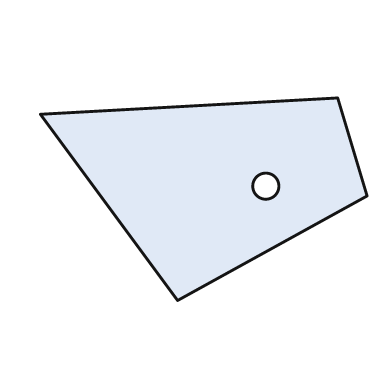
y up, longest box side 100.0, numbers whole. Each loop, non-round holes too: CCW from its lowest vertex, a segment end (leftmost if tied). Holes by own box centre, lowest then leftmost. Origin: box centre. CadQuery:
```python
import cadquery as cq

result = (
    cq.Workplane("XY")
    .moveTo(-8.0, -31.0)
    .lineTo(50.0, 1.0)
    .lineTo(41.0, 31.0)
    .lineTo(-50.0, 26.0)
    .close()
    .moveTo(19.0, 4.0)
    .circle(4.0)
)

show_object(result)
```